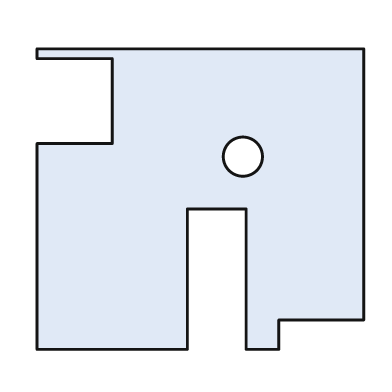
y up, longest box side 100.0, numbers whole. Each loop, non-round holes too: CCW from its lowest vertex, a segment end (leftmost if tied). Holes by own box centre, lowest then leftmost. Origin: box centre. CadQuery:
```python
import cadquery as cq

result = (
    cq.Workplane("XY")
    .moveTo(-50.0, -46.0)
    .lineTo(-4.0, -46.0)
    .lineTo(-4.0, -3.0)
    .lineTo(14.0, -3.0)
    .lineTo(14.0, -46.0)
    .lineTo(24.0, -46.0)
    .lineTo(24.0, -37.0)
    .lineTo(50.0, -37.0)
    .lineTo(50.0, 46.0)
    .lineTo(-50.0, 46.0)
    .lineTo(-50.0, 43.0)
    .lineTo(-27.0, 43.0)
    .lineTo(-27.0, 17.0)
    .lineTo(-50.0, 17.0)
    .close()
    .moveTo(13.0, 13.0)
    .circle(6.0)
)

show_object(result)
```